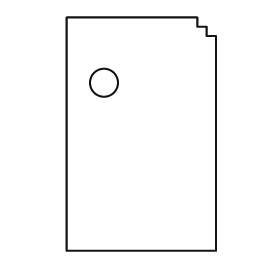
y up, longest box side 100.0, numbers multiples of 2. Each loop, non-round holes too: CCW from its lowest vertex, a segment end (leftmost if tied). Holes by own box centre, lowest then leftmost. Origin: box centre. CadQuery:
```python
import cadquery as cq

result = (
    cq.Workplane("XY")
    .moveTo(-32.0, -50.0)
    .lineTo(32.0, -50.0)
    .lineTo(32.0, 42.0)
    .lineTo(28.0, 42.0)
    .lineTo(28.0, 46.0)
    .lineTo(24.0, 46.0)
    .lineTo(24.0, 50.0)
    .lineTo(-32.0, 50.0)
    .close()
    .moveTo(-16.0, 22.0)
    .circle(6.0)
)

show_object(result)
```